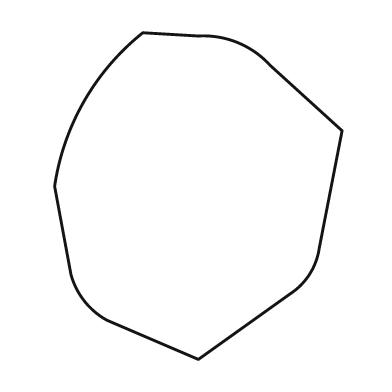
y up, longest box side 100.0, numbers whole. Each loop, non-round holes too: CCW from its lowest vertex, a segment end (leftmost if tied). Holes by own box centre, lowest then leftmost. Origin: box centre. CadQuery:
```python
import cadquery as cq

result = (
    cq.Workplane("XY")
    .moveTo(0.0, -50.0)
    .lineTo(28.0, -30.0)
    .threePointArc((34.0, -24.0), (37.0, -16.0))
    .lineTo(44.0, 20.0)
    .lineTo(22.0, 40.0)
    .threePointArc((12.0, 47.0), (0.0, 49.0))
    .lineTo(-17.0, 50.0)
    .threePointArc((-35.0, 29.0), (-44.0, 3.0))
    .lineTo(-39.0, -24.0)
    .threePointArc((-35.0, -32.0), (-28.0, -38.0))
    .close()
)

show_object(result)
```